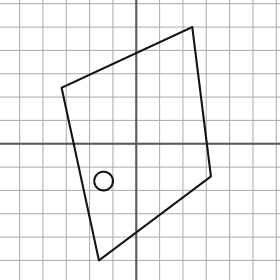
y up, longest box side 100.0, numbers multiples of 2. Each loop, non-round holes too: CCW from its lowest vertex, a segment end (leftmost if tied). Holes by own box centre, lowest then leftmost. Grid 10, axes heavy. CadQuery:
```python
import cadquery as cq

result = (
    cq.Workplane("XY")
    .moveTo(-16.0, -50.0)
    .lineTo(32.0, -14.0)
    .lineTo(24.0, 50.0)
    .lineTo(-32.0, 24.0)
    .close()
    .moveTo(-14.0, -16.0)
    .circle(4.0)
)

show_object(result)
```